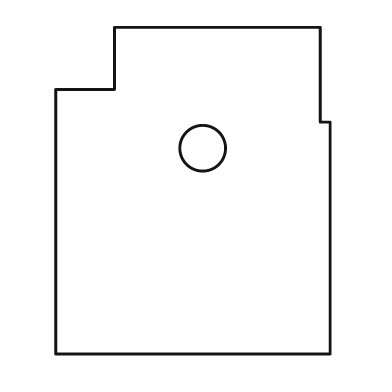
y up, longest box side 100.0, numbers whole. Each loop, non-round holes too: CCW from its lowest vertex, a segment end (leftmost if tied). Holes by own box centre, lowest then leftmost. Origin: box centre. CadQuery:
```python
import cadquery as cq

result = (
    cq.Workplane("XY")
    .moveTo(-42.0, -50.0)
    .lineTo(42.0, -50.0)
    .lineTo(42.0, 21.0)
    .lineTo(39.0, 21.0)
    .lineTo(39.0, 50.0)
    .lineTo(-24.0, 50.0)
    .lineTo(-24.0, 31.0)
    .lineTo(-42.0, 31.0)
    .close()
    .moveTo(3.0, 13.0)
    .circle(7.0)
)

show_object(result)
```